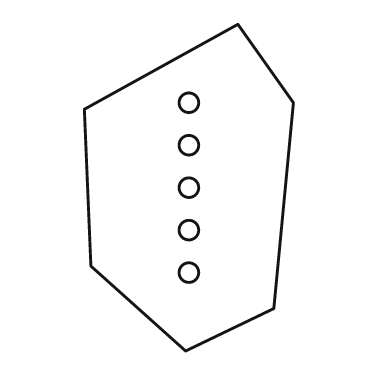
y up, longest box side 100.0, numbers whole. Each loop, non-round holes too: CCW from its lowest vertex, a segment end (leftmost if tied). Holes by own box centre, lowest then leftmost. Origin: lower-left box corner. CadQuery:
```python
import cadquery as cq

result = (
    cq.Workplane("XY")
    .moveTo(31.0, 0.0)
    .lineTo(58.0, 13.0)
    .lineTo(64.0, 76.0)
    .lineTo(47.0, 100.0)
    .lineTo(0.0, 74.0)
    .lineTo(2.0, 26.0)
    .close()
    .moveTo(32.0, 24.0)
    .circle(3.0)
    .moveTo(32.0, 37.0)
    .circle(3.0)
    .moveTo(32.0, 50.0)
    .circle(3.0)
    .moveTo(32.0, 63.0)
    .circle(3.0)
    .moveTo(32.0, 76.0)
    .circle(3.0)
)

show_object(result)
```